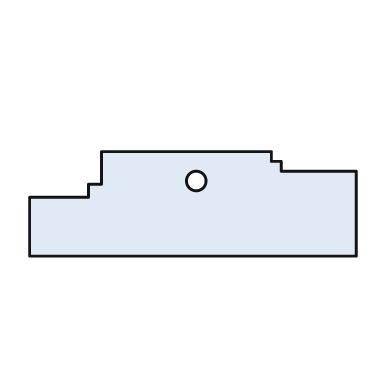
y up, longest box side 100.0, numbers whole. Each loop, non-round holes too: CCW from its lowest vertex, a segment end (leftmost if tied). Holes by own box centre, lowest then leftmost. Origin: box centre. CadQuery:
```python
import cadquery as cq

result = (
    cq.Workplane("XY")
    .moveTo(-50.0, -16.0)
    .lineTo(50.0, -16.0)
    .lineTo(50.0, 10.0)
    .lineTo(27.0, 10.0)
    .lineTo(27.0, 13.0)
    .lineTo(24.0, 13.0)
    .lineTo(24.0, 16.0)
    .lineTo(-28.0, 16.0)
    .lineTo(-28.0, 6.0)
    .lineTo(-32.0, 6.0)
    .lineTo(-32.0, 2.0)
    .lineTo(-50.0, 2.0)
    .close()
    .moveTo(1.0, 7.0)
    .circle(3.0)
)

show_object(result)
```